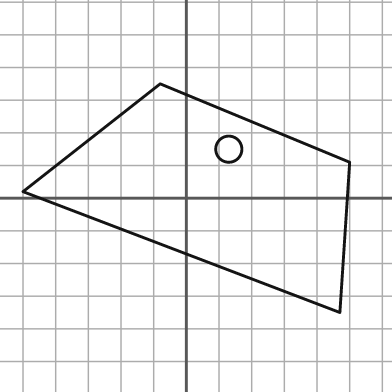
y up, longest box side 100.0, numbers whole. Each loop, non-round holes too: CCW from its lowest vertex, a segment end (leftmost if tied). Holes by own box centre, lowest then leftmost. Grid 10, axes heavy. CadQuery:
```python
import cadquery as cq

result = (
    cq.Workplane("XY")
    .moveTo(47.0, -35.0)
    .lineTo(50.0, 11.0)
    .lineTo(-8.0, 35.0)
    .lineTo(-50.0, 2.0)
    .close()
    .moveTo(13.0, 15.0)
    .circle(4.0)
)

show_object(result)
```